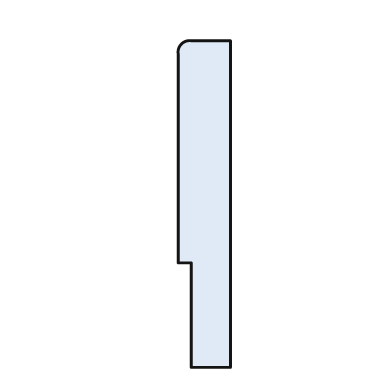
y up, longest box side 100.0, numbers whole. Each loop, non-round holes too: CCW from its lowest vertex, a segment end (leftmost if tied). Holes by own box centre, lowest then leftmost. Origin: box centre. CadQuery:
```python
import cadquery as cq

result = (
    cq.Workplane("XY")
    .moveTo(-4.0, -50.0)
    .lineTo(8.0, -50.0)
    .lineTo(8.0, 50.0)
    .lineTo(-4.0, 50.0)
    .threePointArc((-7.0, 49.0), (-8.0, 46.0))
    .lineTo(-8.0, -18.0)
    .lineTo(-4.0, -18.0)
    .close()
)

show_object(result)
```